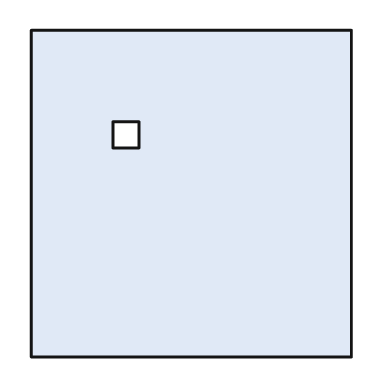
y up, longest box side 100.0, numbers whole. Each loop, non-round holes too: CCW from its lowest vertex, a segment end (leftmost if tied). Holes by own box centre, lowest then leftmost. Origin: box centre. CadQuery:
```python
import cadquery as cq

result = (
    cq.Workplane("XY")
    .moveTo(-49.0, -50.0)
    .lineTo(49.0, -50.0)
    .lineTo(49.0, 50.0)
    .lineTo(-49.0, 50.0)
    .close()
    .moveTo(-24.0, 14.0)
    .lineTo(-16.0, 14.0)
    .lineTo(-16.0, 22.0)
    .lineTo(-24.0, 22.0)
    .close()
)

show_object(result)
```